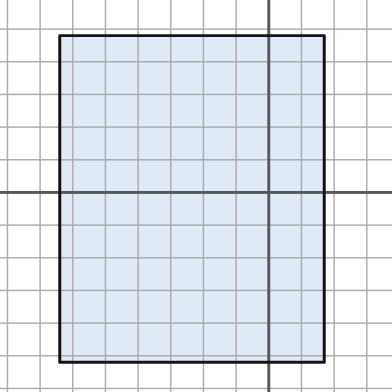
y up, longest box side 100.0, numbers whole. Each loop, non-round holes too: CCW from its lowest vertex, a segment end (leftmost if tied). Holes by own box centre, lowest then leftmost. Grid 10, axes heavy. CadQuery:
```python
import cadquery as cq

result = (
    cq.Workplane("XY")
    .moveTo(-64.0, -52.0)
    .lineTo(17.0, -52.0)
    .lineTo(17.0, 48.0)
    .lineTo(-64.0, 48.0)
    .close()
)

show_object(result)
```